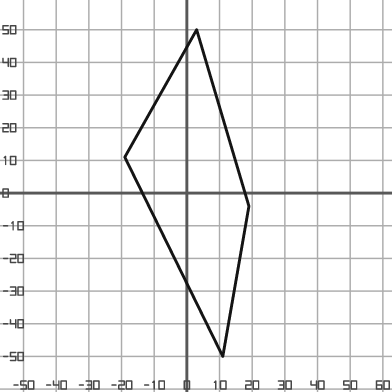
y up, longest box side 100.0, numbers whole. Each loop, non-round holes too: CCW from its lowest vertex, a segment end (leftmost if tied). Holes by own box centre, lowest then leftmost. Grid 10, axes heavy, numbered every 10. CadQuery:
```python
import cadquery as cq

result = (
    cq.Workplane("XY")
    .moveTo(11.0, -50.0)
    .lineTo(19.0, -4.0)
    .lineTo(3.0, 50.0)
    .lineTo(-19.0, 11.0)
    .close()
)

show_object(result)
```